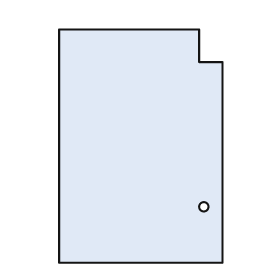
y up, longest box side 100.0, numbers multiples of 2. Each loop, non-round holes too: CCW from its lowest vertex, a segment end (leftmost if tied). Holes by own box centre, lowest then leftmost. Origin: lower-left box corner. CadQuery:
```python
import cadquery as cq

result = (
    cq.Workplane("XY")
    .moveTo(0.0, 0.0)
    .lineTo(70.0, 0.0)
    .lineTo(70.0, 86.0)
    .lineTo(60.0, 86.0)
    .lineTo(60.0, 100.0)
    .lineTo(0.0, 100.0)
    .close()
    .moveTo(62.0, 24.0)
    .circle(2.0)
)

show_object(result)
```